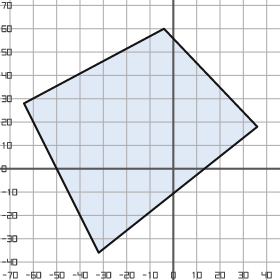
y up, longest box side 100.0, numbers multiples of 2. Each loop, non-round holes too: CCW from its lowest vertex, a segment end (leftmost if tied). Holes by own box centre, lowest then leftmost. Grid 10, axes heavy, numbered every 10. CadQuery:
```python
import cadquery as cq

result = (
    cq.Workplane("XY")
    .moveTo(-32.0, -36.0)
    .lineTo(36.0, 18.0)
    .lineTo(-4.0, 60.0)
    .lineTo(-64.0, 28.0)
    .close()
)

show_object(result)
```